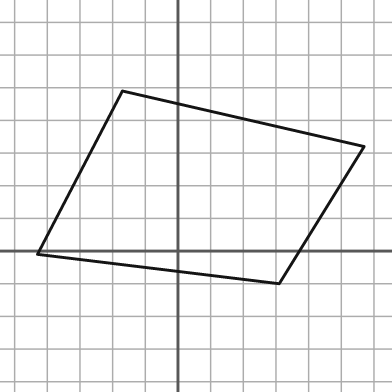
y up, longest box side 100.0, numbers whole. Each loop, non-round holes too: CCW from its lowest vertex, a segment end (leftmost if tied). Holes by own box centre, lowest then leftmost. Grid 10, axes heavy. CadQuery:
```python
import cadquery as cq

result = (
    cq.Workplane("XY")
    .moveTo(31.0, -10.0)
    .lineTo(57.0, 32.0)
    .lineTo(-17.0, 49.0)
    .lineTo(-43.0, -1.0)
    .close()
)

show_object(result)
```